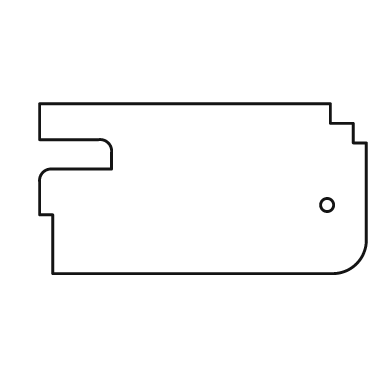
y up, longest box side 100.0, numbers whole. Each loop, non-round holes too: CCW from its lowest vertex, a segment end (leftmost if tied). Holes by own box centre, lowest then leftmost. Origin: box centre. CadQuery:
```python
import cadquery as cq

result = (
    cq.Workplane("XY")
    .moveTo(-46.0, -26.0)
    .lineTo(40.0, -26.0)
    .threePointArc((47.0, -23.0), (50.0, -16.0))
    .lineTo(50.0, 14.0)
    .lineTo(46.0, 14.0)
    .lineTo(46.0, 20.0)
    .lineTo(39.0, 20.0)
    .lineTo(39.0, 26.0)
    .lineTo(-50.0, 26.0)
    .lineTo(-50.0, 15.0)
    .lineTo(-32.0, 15.0)
    .threePointArc((-29.0, 14.0), (-28.0, 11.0))
    .lineTo(-28.0, 6.0)
    .lineTo(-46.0, 6.0)
    .threePointArc((-49.0, 5.0), (-50.0, 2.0))
    .lineTo(-50.0, -8.0)
    .lineTo(-46.0, -8.0)
    .close()
    .moveTo(38.0, -5.0)
    .circle(2.0)
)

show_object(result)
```